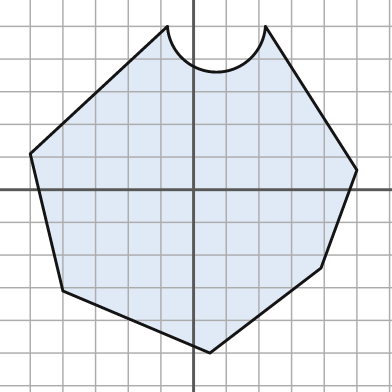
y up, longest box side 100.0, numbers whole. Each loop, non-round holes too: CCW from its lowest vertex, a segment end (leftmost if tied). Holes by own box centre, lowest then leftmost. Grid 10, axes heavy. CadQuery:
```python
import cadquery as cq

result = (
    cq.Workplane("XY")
    .moveTo(5.0, -50.0)
    .lineTo(39.0, -24.0)
    .lineTo(50.0, 6.0)
    .lineTo(22.0, 50.0)
    .threePointArc((7.0, 36.0), (-8.0, 50.0))
    .lineTo(-50.0, 11.0)
    .lineTo(-40.0, -31.0)
    .close()
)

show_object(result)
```